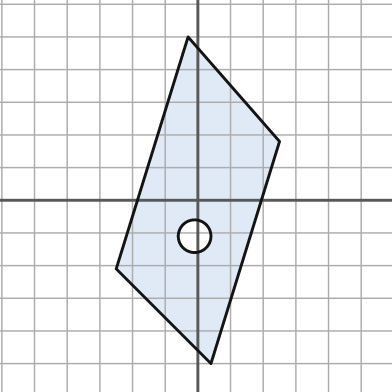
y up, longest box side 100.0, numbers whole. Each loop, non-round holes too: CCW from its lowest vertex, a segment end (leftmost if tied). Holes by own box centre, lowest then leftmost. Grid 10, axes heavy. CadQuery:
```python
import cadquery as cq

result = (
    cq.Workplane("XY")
    .moveTo(4.0, -50.0)
    .lineTo(25.0, 18.0)
    .lineTo(-3.0, 50.0)
    .lineTo(-25.0, -21.0)
    .close()
    .moveTo(-1.0, -11.0)
    .circle(5.0)
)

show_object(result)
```